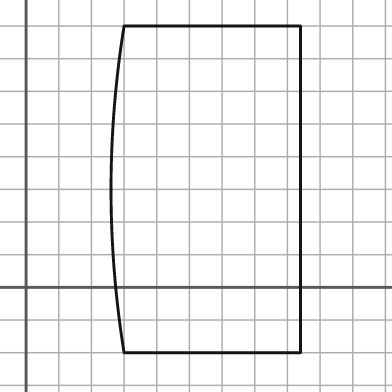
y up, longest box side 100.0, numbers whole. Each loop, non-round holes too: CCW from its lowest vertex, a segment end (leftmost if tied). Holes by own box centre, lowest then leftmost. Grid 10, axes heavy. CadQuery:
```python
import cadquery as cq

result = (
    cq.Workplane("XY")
    .moveTo(30.0, -20.0)
    .lineTo(84.0, -20.0)
    .lineTo(84.0, 80.0)
    .lineTo(30.0, 80.0)
    .threePointArc((26.0, 30.0), (30.0, -20.0))
    .close()
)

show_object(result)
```